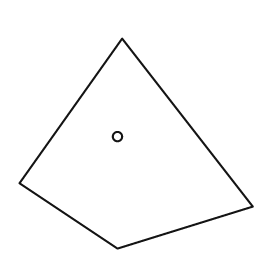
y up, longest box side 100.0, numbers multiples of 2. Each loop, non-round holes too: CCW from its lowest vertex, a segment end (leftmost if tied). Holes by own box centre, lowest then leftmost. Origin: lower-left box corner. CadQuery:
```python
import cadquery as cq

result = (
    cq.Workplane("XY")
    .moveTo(42.0, 0.0)
    .lineTo(100.0, 18.0)
    .lineTo(44.0, 90.0)
    .lineTo(0.0, 28.0)
    .close()
    .moveTo(42.0, 48.0)
    .circle(2.0)
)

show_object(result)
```